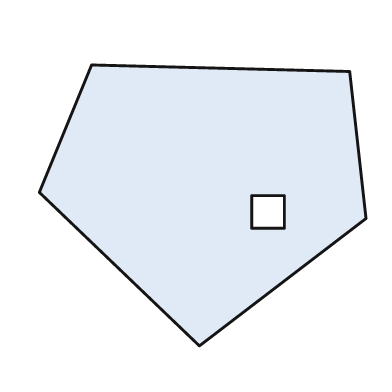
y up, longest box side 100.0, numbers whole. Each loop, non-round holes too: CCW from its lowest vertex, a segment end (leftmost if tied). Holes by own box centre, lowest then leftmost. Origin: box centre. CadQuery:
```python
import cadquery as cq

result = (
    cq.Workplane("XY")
    .moveTo(-1.0, -43.0)
    .lineTo(50.0, -4.0)
    .lineTo(45.0, 41.0)
    .lineTo(-34.0, 43.0)
    .lineTo(-50.0, 4.0)
    .close()
    .moveTo(15.0, -7.0)
    .lineTo(25.0, -7.0)
    .lineTo(25.0, 3.0)
    .lineTo(15.0, 3.0)
    .close()
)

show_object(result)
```